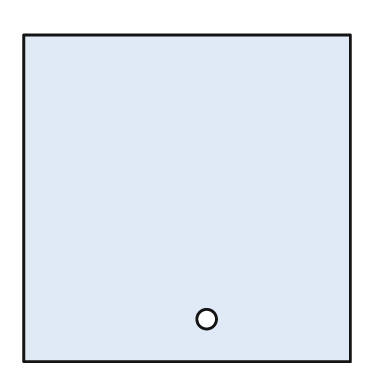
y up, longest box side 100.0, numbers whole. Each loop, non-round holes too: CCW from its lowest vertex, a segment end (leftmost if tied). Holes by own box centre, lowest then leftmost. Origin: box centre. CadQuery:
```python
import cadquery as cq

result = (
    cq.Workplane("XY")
    .moveTo(-50.0, -50.0)
    .lineTo(50.0, -50.0)
    .lineTo(50.0, 50.0)
    .lineTo(-50.0, 50.0)
    .close()
    .moveTo(6.0, -37.0)
    .circle(3.0)
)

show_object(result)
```